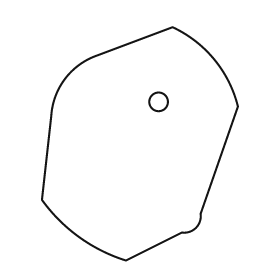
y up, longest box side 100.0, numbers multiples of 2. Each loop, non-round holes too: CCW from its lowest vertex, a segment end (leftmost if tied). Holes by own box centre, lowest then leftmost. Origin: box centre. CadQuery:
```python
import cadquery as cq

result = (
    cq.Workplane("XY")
    .moveTo(-6.0, -50.0)
    .lineTo(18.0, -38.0)
    .threePointArc((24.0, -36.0), (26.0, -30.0))
    .lineTo(42.0, 16.0)
    .threePointArc((32.0, 36.0), (14.0, 50.0))
    .lineTo(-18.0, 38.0)
    .threePointArc((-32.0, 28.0), (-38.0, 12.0))
    .lineTo(-42.0, -24.0)
    .threePointArc((-26.0, -40.0), (-6.0, -50.0))
    .close()
    .moveTo(8.0, 18.0)
    .circle(4.0)
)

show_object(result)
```